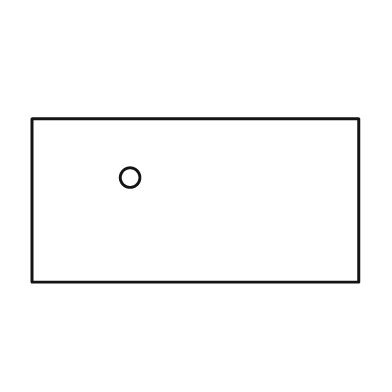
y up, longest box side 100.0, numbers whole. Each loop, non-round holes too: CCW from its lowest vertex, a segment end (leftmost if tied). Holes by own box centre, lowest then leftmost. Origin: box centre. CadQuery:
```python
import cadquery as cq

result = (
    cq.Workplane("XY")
    .moveTo(-50.0, -25.0)
    .lineTo(50.0, -25.0)
    .lineTo(50.0, 25.0)
    .lineTo(-50.0, 25.0)
    .close()
    .moveTo(-20.0, 7.0)
    .circle(3.0)
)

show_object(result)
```